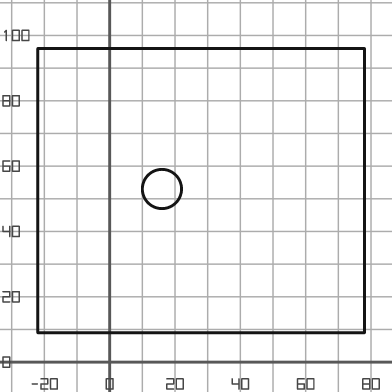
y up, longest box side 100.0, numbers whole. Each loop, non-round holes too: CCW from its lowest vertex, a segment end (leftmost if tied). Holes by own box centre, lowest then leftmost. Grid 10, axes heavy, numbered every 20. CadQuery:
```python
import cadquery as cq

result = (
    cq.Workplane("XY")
    .moveTo(-22.0, 9.0)
    .lineTo(78.0, 9.0)
    .lineTo(78.0, 96.0)
    .lineTo(-22.0, 96.0)
    .close()
    .moveTo(16.0, 53.0)
    .circle(6.0)
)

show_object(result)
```